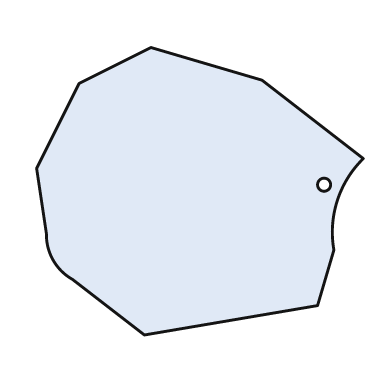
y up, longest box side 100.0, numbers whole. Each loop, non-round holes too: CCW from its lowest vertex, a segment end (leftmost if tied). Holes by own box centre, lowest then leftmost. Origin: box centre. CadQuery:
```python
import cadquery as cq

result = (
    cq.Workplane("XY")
    .moveTo(-17.0, -44.0)
    .lineTo(36.0, -35.0)
    .lineTo(41.0, -18.0)
    .threePointArc((42.0, -3.0), (50.0, 10.0))
    .lineTo(19.0, 34.0)
    .lineTo(-15.0, 44.0)
    .lineTo(-37.0, 33.0)
    .lineTo(-50.0, 7.0)
    .lineTo(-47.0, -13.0)
    .threePointArc((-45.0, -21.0), (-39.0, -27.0))
    .close()
    .moveTo(38.0, 2.0)
    .circle(2.0)
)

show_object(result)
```